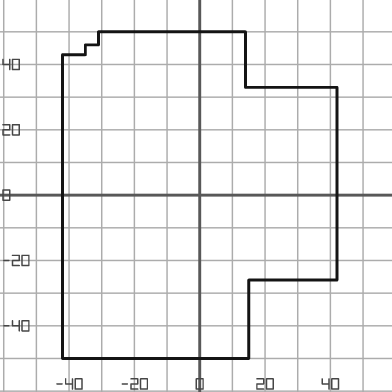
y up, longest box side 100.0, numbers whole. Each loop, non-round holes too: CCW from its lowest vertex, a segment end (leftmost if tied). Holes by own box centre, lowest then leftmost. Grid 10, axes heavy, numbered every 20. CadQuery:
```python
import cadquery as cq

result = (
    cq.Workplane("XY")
    .moveTo(-42.0, -50.0)
    .lineTo(15.0, -50.0)
    .lineTo(15.0, -26.0)
    .lineTo(42.0, -26.0)
    .lineTo(42.0, 33.0)
    .lineTo(14.0, 33.0)
    .lineTo(14.0, 50.0)
    .lineTo(-31.0, 50.0)
    .lineTo(-31.0, 46.0)
    .lineTo(-35.0, 46.0)
    .lineTo(-35.0, 43.0)
    .lineTo(-42.0, 43.0)
    .close()
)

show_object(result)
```